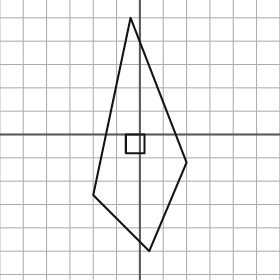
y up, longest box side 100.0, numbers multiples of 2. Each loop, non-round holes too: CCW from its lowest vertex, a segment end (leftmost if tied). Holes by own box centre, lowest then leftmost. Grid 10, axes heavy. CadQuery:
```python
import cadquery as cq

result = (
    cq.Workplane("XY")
    .moveTo(4.0, -50.0)
    .lineTo(20.0, -12.0)
    .lineTo(-4.0, 50.0)
    .lineTo(-20.0, -26.0)
    .close()
    .moveTo(-6.0, -8.0)
    .lineTo(2.0, -8.0)
    .lineTo(2.0, 0.0)
    .lineTo(-6.0, 0.0)
    .close()
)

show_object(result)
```